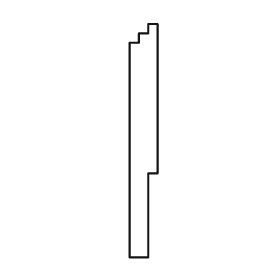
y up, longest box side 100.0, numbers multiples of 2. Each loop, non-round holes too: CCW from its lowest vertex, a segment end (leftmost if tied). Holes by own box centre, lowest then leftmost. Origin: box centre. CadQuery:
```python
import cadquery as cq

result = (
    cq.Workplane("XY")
    .moveTo(-6.0, -50.0)
    .lineTo(2.0, -50.0)
    .lineTo(2.0, -14.0)
    .lineTo(6.0, -14.0)
    .lineTo(6.0, 50.0)
    .lineTo(2.0, 50.0)
    .lineTo(2.0, 46.0)
    .lineTo(-2.0, 46.0)
    .lineTo(-2.0, 42.0)
    .lineTo(-6.0, 42.0)
    .close()
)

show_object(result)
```